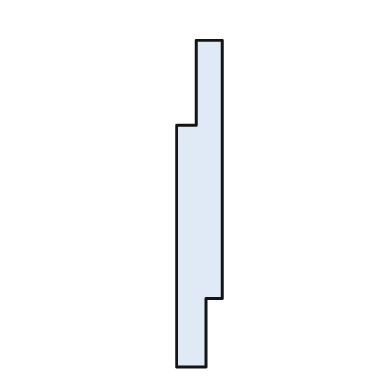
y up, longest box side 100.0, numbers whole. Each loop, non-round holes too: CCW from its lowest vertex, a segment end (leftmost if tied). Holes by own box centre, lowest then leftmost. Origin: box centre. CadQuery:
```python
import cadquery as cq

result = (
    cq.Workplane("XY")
    .moveTo(-7.0, -50.0)
    .lineTo(2.0, -50.0)
    .lineTo(2.0, -29.0)
    .lineTo(7.0, -29.0)
    .lineTo(7.0, 50.0)
    .lineTo(-1.0, 50.0)
    .lineTo(-1.0, 24.0)
    .lineTo(-7.0, 24.0)
    .close()
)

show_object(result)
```